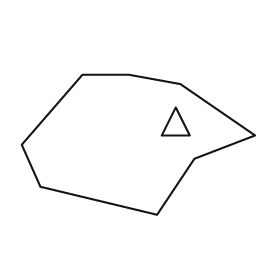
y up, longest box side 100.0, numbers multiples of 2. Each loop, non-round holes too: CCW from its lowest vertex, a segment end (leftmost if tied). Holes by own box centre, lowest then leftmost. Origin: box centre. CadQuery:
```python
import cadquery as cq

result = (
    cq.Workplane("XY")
    .moveTo(8.0, -30.0)
    .lineTo(24.0, -6.0)
    .lineTo(50.0, 4.0)
    .lineTo(18.0, 26.0)
    .lineTo(-4.0, 30.0)
    .lineTo(-24.0, 30.0)
    .lineTo(-50.0, 0.0)
    .lineTo(-42.0, -18.0)
    .close()
    .moveTo(10.0, 4.0)
    .lineTo(22.0, 4.0)
    .lineTo(16.0, 16.0)
    .close()
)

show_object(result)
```